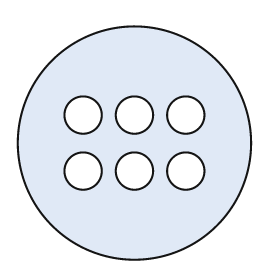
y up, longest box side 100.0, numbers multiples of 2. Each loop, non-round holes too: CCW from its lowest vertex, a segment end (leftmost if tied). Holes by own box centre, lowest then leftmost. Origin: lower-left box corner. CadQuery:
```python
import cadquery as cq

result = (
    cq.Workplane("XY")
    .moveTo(50.0, 50.0)
    .circle(50.0)
    .moveTo(28.0, 38.0)
    .circle(8.0)
    .moveTo(50.0, 38.0)
    .circle(8.0)
    .moveTo(72.0, 38.0)
    .circle(8.0)
    .moveTo(28.0, 62.0)
    .circle(8.0)
    .moveTo(50.0, 62.0)
    .circle(8.0)
    .moveTo(72.0, 62.0)
    .circle(8.0)
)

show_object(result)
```